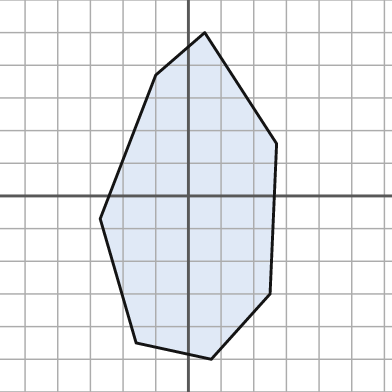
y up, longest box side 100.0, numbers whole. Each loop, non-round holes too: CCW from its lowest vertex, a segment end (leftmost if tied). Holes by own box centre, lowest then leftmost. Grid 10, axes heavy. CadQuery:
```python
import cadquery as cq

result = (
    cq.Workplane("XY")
    .moveTo(7.0, -50.0)
    .lineTo(25.0, -30.0)
    .lineTo(27.0, 16.0)
    .lineTo(5.0, 50.0)
    .lineTo(-10.0, 37.0)
    .lineTo(-27.0, -7.0)
    .lineTo(-16.0, -45.0)
    .close()
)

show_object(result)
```